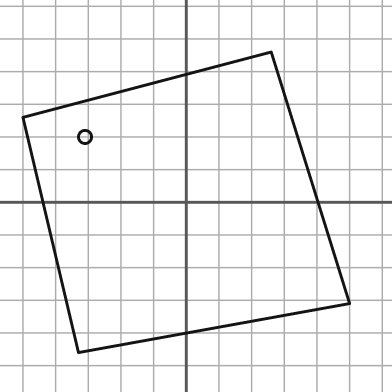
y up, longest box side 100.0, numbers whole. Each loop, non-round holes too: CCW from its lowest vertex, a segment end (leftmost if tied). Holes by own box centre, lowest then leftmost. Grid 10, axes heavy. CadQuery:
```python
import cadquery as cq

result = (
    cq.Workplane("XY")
    .moveTo(-33.0, -46.0)
    .lineTo(50.0, -31.0)
    .lineTo(26.0, 46.0)
    .lineTo(-50.0, 26.0)
    .close()
    .moveTo(-31.0, 20.0)
    .circle(2.0)
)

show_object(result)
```